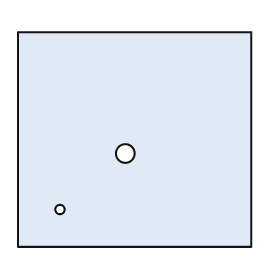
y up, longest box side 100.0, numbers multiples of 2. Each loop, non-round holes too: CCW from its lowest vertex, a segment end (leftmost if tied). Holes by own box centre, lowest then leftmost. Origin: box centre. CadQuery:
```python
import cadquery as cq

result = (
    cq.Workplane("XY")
    .moveTo(-50.0, -46.0)
    .lineTo(50.0, -46.0)
    .lineTo(50.0, 46.0)
    .lineTo(-50.0, 46.0)
    .close()
    .moveTo(-32.0, -30.0)
    .circle(2.0)
    .moveTo(-4.0, -6.0)
    .circle(4.0)
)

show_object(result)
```